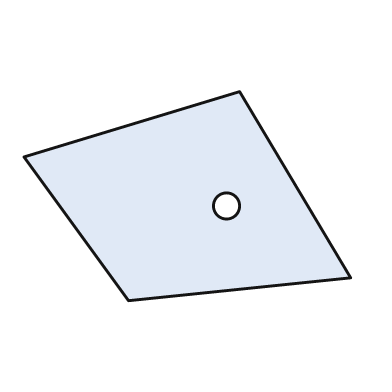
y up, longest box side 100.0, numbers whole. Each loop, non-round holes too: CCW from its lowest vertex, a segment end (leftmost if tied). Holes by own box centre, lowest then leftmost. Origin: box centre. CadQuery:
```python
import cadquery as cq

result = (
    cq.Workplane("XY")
    .moveTo(-18.0, -32.0)
    .lineTo(50.0, -25.0)
    .lineTo(16.0, 32.0)
    .lineTo(-50.0, 12.0)
    .close()
    .moveTo(12.0, -3.0)
    .circle(4.0)
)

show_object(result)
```